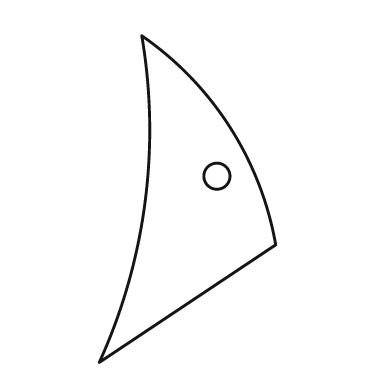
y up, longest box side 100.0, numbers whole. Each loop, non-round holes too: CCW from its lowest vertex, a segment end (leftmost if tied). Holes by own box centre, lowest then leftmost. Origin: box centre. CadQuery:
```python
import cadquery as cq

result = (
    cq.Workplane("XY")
    .moveTo(-27.0, -50.0)
    .lineTo(27.0, -14.0)
    .threePointArc((13.0, 22.0), (-14.0, 50.0))
    .threePointArc((-13.0, -1.0), (-27.0, -50.0))
    .close()
    .moveTo(9.0, 7.0)
    .circle(4.0)
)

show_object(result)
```